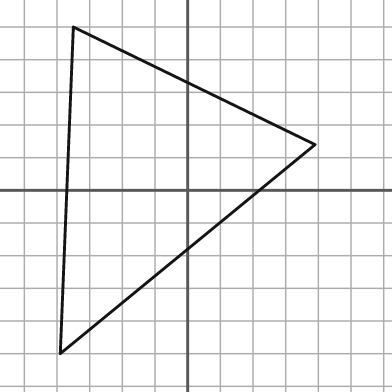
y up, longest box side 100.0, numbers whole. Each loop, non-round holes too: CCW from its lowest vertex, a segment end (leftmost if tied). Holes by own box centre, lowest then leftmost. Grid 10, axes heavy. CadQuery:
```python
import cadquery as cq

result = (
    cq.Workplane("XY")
    .moveTo(-39.0, -50.0)
    .lineTo(39.0, 14.0)
    .lineTo(-35.0, 50.0)
    .close()
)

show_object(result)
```